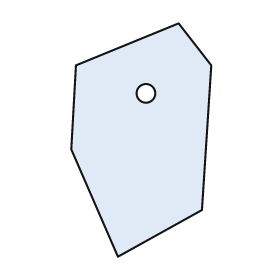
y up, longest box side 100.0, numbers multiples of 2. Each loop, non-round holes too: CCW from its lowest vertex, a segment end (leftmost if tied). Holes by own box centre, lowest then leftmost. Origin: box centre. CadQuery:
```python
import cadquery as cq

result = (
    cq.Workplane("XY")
    .moveTo(-10.0, -50.0)
    .lineTo(26.0, -30.0)
    .lineTo(30.0, 32.0)
    .lineTo(16.0, 50.0)
    .lineTo(-28.0, 32.0)
    .lineTo(-30.0, -4.0)
    .close()
    .moveTo(2.0, 20.0)
    .circle(4.0)
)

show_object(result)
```